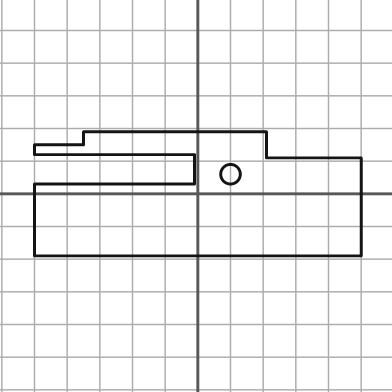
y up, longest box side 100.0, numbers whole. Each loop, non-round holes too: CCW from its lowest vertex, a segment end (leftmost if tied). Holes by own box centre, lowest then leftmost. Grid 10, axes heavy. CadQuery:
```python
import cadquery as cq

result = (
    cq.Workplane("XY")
    .moveTo(-50.0, -19.0)
    .lineTo(50.0, -19.0)
    .lineTo(50.0, 11.0)
    .lineTo(21.0, 11.0)
    .lineTo(21.0, 19.0)
    .lineTo(-35.0, 19.0)
    .lineTo(-35.0, 15.0)
    .lineTo(-50.0, 15.0)
    .lineTo(-50.0, 12.0)
    .lineTo(-1.0, 12.0)
    .lineTo(-1.0, 3.0)
    .lineTo(-50.0, 3.0)
    .close()
    .moveTo(10.0, 6.0)
    .circle(3.0)
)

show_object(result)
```